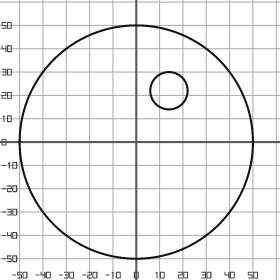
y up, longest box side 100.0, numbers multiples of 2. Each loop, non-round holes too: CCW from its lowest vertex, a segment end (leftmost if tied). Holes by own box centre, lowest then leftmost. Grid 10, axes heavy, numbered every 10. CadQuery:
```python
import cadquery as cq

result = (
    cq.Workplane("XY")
    .moveTo(0.0, 0.0)
    .circle(50.0)
    .moveTo(14.0, 22.0)
    .circle(8.0)
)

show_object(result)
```